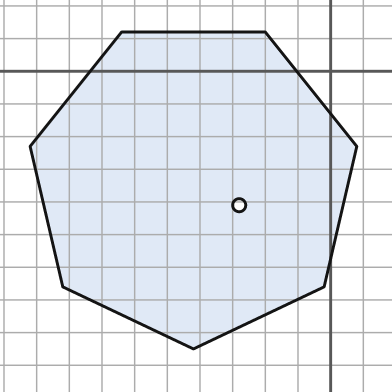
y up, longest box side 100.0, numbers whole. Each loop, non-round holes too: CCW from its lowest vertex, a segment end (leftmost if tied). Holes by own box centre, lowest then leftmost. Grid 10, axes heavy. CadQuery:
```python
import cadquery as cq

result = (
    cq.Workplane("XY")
    .moveTo(-42.0, -85.0)
    .lineTo(-2.0, -66.0)
    .lineTo(8.0, -23.0)
    .lineTo(-20.0, 12.0)
    .lineTo(-64.0, 12.0)
    .lineTo(-92.0, -23.0)
    .lineTo(-82.0, -66.0)
    .close()
    .moveTo(-28.0, -41.0)
    .circle(2.0)
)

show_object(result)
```